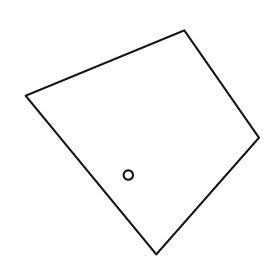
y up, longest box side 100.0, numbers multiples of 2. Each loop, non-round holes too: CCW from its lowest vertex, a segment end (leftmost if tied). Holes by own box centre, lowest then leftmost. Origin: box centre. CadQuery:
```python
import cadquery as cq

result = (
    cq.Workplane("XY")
    .moveTo(6.0, -48.0)
    .lineTo(50.0, 2.0)
    .lineTo(18.0, 48.0)
    .lineTo(-50.0, 20.0)
    .close()
    .moveTo(-6.0, -14.0)
    .circle(2.0)
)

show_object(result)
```